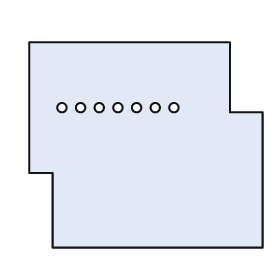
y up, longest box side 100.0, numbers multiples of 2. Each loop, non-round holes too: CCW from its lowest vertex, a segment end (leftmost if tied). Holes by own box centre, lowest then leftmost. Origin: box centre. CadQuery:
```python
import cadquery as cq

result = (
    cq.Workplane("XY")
    .moveTo(-40.0, -44.0)
    .lineTo(50.0, -44.0)
    .lineTo(50.0, 14.0)
    .lineTo(36.0, 14.0)
    .lineTo(36.0, 44.0)
    .lineTo(-50.0, 44.0)
    .lineTo(-50.0, -12.0)
    .lineTo(-40.0, -12.0)
    .close()
    .moveTo(-36.0, 16.0)
    .circle(2.0)
    .moveTo(-28.0, 16.0)
    .circle(2.0)
    .moveTo(-20.0, 16.0)
    .circle(2.0)
    .moveTo(-12.0, 16.0)
    .circle(2.0)
    .moveTo(-4.0, 16.0)
    .circle(2.0)
    .moveTo(4.0, 16.0)
    .circle(2.0)
    .moveTo(12.0, 16.0)
    .circle(2.0)
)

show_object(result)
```